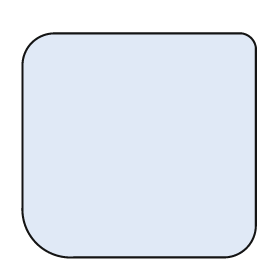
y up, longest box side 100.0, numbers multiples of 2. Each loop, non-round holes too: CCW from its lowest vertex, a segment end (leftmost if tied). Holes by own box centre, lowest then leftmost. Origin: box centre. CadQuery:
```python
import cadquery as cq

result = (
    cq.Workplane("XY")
    .moveTo(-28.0, -48.0)
    .lineTo(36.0, -48.0)
    .threePointArc((46.0, -44.0), (50.0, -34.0))
    .lineTo(50.0, 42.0)
    .threePointArc((48.0, 46.0), (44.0, 48.0))
    .lineTo(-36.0, 48.0)
    .threePointArc((-46.0, 44.0), (-50.0, 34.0))
    .lineTo(-50.0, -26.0)
    .threePointArc((-44.0, -42.0), (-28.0, -48.0))
    .close()
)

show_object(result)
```